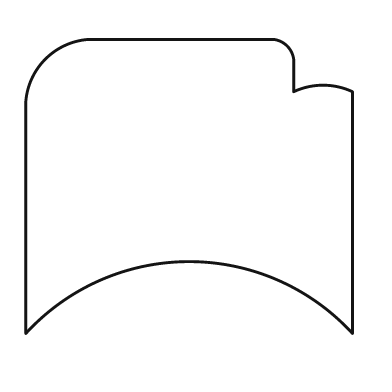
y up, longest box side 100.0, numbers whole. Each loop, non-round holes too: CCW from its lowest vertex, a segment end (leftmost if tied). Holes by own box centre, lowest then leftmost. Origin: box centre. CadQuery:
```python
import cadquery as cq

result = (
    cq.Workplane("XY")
    .moveTo(-50.0, -45.0)
    .threePointArc((0.0, -23.0), (50.0, -45.0))
    .lineTo(50.0, 29.0)
    .threePointArc((41.0, 31.0), (32.0, 29.0))
    .lineTo(32.0, 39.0)
    .threePointArc((30.0, 43.0), (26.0, 45.0))
    .lineTo(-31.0, 45.0)
    .threePointArc((-44.0, 39.0), (-50.0, 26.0))
    .close()
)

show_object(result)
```